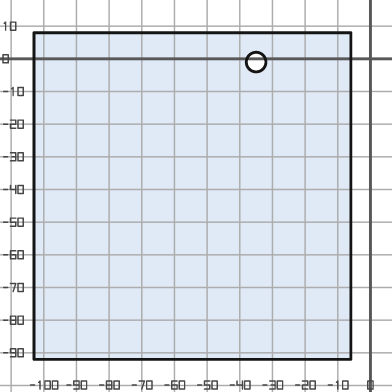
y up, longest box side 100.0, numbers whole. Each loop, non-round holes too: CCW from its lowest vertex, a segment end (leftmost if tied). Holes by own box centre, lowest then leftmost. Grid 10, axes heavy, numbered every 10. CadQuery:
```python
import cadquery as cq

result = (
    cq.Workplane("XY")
    .moveTo(-103.0, -92.0)
    .lineTo(-6.0, -92.0)
    .lineTo(-6.0, 8.0)
    .lineTo(-103.0, 8.0)
    .close()
    .moveTo(-35.0, -1.0)
    .circle(3.0)
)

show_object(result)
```